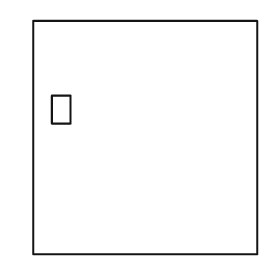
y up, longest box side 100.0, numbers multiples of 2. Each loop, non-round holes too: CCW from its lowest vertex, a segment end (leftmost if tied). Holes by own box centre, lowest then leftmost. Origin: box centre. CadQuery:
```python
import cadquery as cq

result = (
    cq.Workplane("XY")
    .moveTo(-48.0, -50.0)
    .lineTo(48.0, -50.0)
    .lineTo(48.0, 50.0)
    .lineTo(-48.0, 50.0)
    .close()
    .moveTo(-40.0, 6.0)
    .lineTo(-32.0, 6.0)
    .lineTo(-32.0, 18.0)
    .lineTo(-40.0, 18.0)
    .close()
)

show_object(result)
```